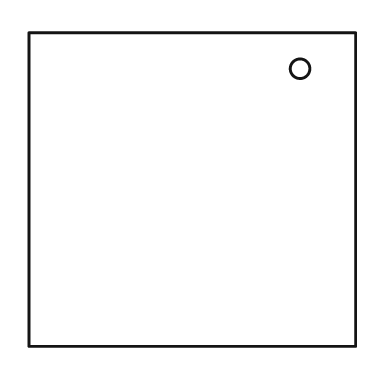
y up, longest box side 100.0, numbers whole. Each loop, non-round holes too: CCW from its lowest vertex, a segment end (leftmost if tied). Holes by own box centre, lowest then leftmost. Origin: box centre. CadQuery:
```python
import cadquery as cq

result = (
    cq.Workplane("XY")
    .moveTo(-50.0, -48.0)
    .lineTo(50.0, -48.0)
    .lineTo(50.0, 48.0)
    .lineTo(-50.0, 48.0)
    .close()
    .moveTo(33.0, 37.0)
    .circle(3.0)
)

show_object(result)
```